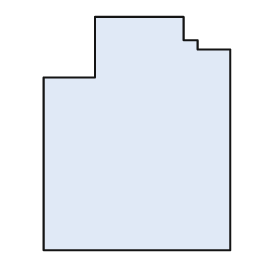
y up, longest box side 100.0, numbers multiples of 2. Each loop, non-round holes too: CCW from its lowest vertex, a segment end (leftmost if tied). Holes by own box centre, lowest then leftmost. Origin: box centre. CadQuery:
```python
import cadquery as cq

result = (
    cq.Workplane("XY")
    .moveTo(-40.0, -50.0)
    .lineTo(40.0, -50.0)
    .lineTo(40.0, 36.0)
    .lineTo(26.0, 36.0)
    .lineTo(26.0, 40.0)
    .lineTo(20.0, 40.0)
    .lineTo(20.0, 50.0)
    .lineTo(-18.0, 50.0)
    .lineTo(-18.0, 24.0)
    .lineTo(-40.0, 24.0)
    .close()
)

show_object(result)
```